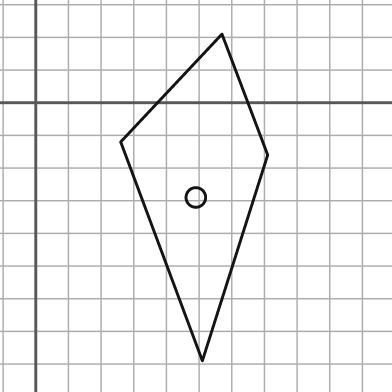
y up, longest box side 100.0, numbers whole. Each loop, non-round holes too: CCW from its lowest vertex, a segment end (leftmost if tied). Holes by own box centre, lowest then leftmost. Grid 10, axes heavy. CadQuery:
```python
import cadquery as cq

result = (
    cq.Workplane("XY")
    .moveTo(51.0, -79.0)
    .lineTo(71.0, -16.0)
    .lineTo(57.0, 21.0)
    .lineTo(26.0, -12.0)
    .close()
    .moveTo(49.0, -29.0)
    .circle(3.0)
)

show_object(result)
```